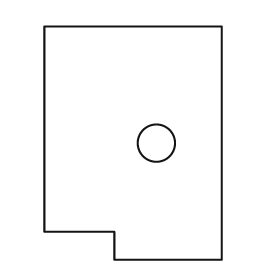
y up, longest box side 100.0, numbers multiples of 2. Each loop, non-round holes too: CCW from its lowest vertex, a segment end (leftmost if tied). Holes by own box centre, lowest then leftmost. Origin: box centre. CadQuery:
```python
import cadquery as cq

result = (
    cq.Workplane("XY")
    .moveTo(-8.0, -50.0)
    .lineTo(38.0, -50.0)
    .lineTo(38.0, 50.0)
    .lineTo(-38.0, 50.0)
    .lineTo(-38.0, -38.0)
    .lineTo(-8.0, -38.0)
    .close()
    .moveTo(10.0, 0.0)
    .circle(8.0)
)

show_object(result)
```